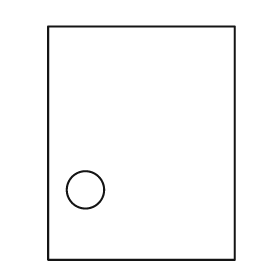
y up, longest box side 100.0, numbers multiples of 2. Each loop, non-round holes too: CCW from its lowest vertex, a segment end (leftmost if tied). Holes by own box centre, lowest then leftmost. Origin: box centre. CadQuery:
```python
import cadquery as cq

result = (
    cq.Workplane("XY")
    .moveTo(-40.0, -50.0)
    .lineTo(40.0, -50.0)
    .lineTo(40.0, 50.0)
    .lineTo(-40.0, 50.0)
    .close()
    .moveTo(-24.0, -20.0)
    .circle(8.0)
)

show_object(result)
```